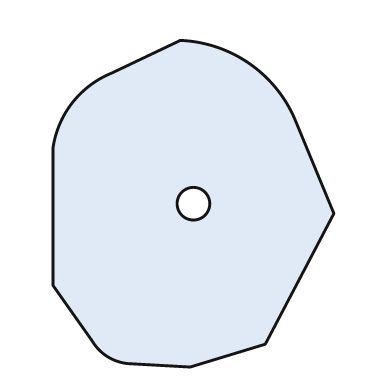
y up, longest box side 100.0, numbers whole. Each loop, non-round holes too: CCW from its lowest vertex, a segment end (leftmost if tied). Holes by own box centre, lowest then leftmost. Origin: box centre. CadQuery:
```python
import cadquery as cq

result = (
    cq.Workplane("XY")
    .moveTo(-1.0, -50.0)
    .lineTo(22.0, -43.0)
    .lineTo(43.0, -3.0)
    .lineTo(31.0, 26.0)
    .threePointArc((17.0, 43.0), (-4.0, 50.0))
    .lineTo(-25.0, 40.0)
    .threePointArc((-37.0, 31.0), (-43.0, 17.0))
    .lineTo(-43.0, -25.0)
    .lineTo(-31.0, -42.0)
    .threePointArc((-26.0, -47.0), (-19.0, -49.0))
    .close()
    .moveTo(0.0, 0.0)
    .circle(5.0)
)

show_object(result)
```